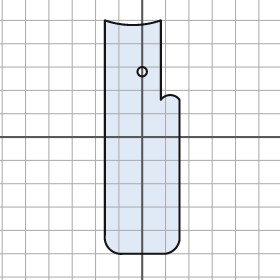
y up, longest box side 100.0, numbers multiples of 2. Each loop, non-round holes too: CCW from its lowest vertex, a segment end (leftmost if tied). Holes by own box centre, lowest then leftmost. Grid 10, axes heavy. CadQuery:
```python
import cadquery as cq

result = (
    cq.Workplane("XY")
    .moveTo(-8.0, -50.0)
    .lineTo(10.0, -50.0)
    .threePointArc((14.0, -48.0), (16.0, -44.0))
    .lineTo(16.0, 16.0)
    .threePointArc((12.0, 18.0), (8.0, 16.0))
    .lineTo(8.0, 50.0)
    .threePointArc((-4.0, 48.0), (-16.0, 50.0))
    .lineTo(-16.0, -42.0)
    .threePointArc((-14.0, -48.0), (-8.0, -50.0))
    .close()
    .moveTo(0.0, 28.0)
    .circle(2.0)
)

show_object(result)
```